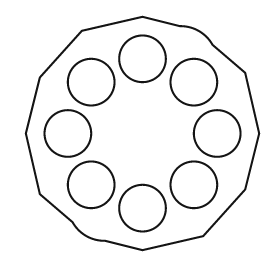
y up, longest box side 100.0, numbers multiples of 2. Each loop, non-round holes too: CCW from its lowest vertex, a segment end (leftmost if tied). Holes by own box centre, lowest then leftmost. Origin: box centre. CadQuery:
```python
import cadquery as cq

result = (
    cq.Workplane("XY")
    .moveTo(0.0, -50.0)
    .lineTo(26.0, -44.0)
    .lineTo(44.0, -24.0)
    .lineTo(50.0, 0.0)
    .lineTo(44.0, 26.0)
    .lineTo(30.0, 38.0)
    .threePointArc((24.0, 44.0), (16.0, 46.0))
    .lineTo(0.0, 50.0)
    .lineTo(-26.0, 44.0)
    .lineTo(-44.0, 24.0)
    .lineTo(-50.0, 0.0)
    .lineTo(-44.0, -26.0)
    .lineTo(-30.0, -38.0)
    .threePointArc((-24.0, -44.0), (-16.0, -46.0))
    .close()
    .moveTo(0.0, -32.0)
    .circle(10.0)
    .moveTo(-22.0, -22.0)
    .circle(10.0)
    .moveTo(22.0, -22.0)
    .circle(10.0)
    .moveTo(-32.0, 0.0)
    .circle(10.0)
    .moveTo(32.0, 0.0)
    .circle(10.0)
    .moveTo(-22.0, 22.0)
    .circle(10.0)
    .moveTo(22.0, 22.0)
    .circle(10.0)
    .moveTo(0.0, 32.0)
    .circle(10.0)
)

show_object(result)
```